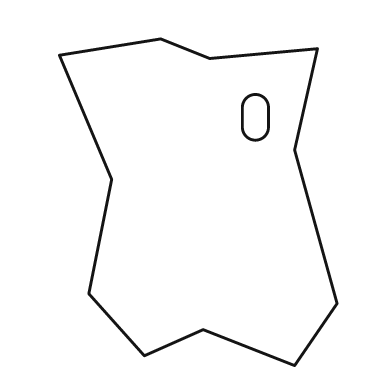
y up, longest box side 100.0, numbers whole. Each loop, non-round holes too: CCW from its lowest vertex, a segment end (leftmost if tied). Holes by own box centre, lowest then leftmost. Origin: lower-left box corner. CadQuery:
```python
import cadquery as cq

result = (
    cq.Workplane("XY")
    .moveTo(72.0, 0.0)
    .lineTo(85.0, 19.0)
    .lineTo(72.0, 66.0)
    .lineTo(79.0, 97.0)
    .lineTo(46.0, 94.0)
    .lineTo(31.0, 100.0)
    .lineTo(0.0, 95.0)
    .lineTo(16.0, 57.0)
    .lineTo(9.0, 22.0)
    .lineTo(26.0, 3.0)
    .lineTo(44.0, 11.0)
    .close()
    .moveTo(56.0, 73.0)
    .threePointArc((60.0, 69.0), (64.0, 73.0))
    .lineTo(64.0, 79.0)
    .threePointArc((60.0, 83.0), (56.0, 79.0))
    .close()
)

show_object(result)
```